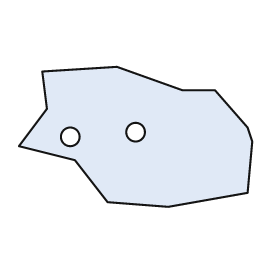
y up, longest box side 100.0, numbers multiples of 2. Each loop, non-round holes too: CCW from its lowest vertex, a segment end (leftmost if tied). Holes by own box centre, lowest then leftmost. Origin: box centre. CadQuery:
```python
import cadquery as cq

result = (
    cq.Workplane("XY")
    .moveTo(14.0, -30.0)
    .lineTo(48.0, -24.0)
    .lineTo(50.0, -2.0)
    .lineTo(48.0, 4.0)
    .lineTo(34.0, 20.0)
    .lineTo(20.0, 20.0)
    .lineTo(-8.0, 30.0)
    .lineTo(-40.0, 28.0)
    .lineTo(-38.0, 12.0)
    .lineTo(-50.0, -4.0)
    .lineTo(-26.0, -10.0)
    .lineTo(-12.0, -28.0)
    .close()
    .moveTo(-28.0, 0.0)
    .circle(4.0)
    .moveTo(0.0, 2.0)
    .circle(4.0)
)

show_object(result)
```